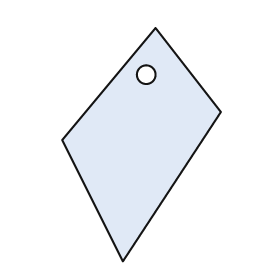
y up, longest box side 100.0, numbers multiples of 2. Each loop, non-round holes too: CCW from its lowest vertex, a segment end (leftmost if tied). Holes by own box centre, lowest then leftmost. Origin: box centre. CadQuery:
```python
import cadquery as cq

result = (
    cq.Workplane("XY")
    .moveTo(-8.0, -50.0)
    .lineTo(34.0, 14.0)
    .lineTo(6.0, 50.0)
    .lineTo(-34.0, 2.0)
    .close()
    .moveTo(2.0, 30.0)
    .circle(4.0)
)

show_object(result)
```